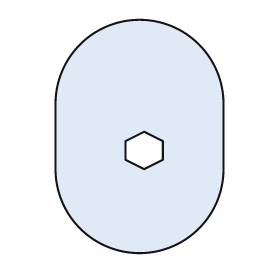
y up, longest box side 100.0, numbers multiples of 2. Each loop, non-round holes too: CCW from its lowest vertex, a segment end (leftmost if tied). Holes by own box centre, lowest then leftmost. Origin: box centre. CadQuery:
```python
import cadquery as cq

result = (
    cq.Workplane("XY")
    .moveTo(-36.0, -14.0)
    .threePointArc((0.0, -50.0), (36.0, -14.0))
    .lineTo(36.0, 14.0)
    .threePointArc((0.0, 50.0), (-36.0, 14.0))
    .close()
    .moveTo(2.0, -14.0)
    .lineTo(10.0, -10.0)
    .lineTo(10.0, -2.0)
    .lineTo(2.0, 2.0)
    .lineTo(-6.0, -2.0)
    .lineTo(-6.0, -10.0)
    .close()
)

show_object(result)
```